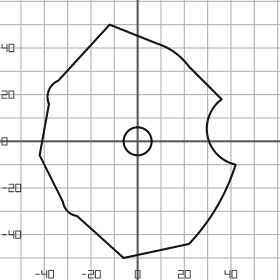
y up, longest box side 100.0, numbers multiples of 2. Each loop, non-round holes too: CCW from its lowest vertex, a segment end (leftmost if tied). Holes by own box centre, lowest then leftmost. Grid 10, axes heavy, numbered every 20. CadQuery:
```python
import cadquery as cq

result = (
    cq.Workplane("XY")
    .moveTo(-6.0, -50.0)
    .lineTo(22.0, -44.0)
    .threePointArc((34.0, -28.0), (42.0, -10.0))
    .threePointArc((30.0, 2.0), (36.0, 18.0))
    .lineTo(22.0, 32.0)
    .threePointArc((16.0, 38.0), (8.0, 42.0))
    .lineTo(-12.0, 50.0)
    .lineTo(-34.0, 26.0)
    .threePointArc((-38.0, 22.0), (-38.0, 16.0))
    .lineTo(-42.0, -6.0)
    .lineTo(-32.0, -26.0)
    .threePointArc((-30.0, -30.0), (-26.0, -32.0))
    .close()
    .moveTo(0.0, 0.0)
    .circle(6.0)
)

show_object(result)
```